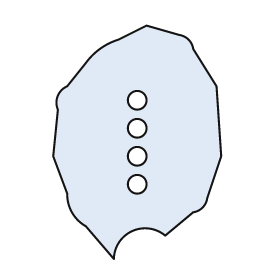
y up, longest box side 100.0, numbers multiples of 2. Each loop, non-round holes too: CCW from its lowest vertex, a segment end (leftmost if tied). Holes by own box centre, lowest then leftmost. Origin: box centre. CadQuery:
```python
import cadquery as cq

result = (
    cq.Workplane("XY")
    .moveTo(-10.0, -50.0)
    .threePointArc((-2.0, -38.0), (12.0, -40.0))
    .lineTo(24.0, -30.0)
    .threePointArc((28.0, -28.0), (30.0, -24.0))
    .lineTo(36.0, -6.0)
    .lineTo(34.0, 24.0)
    .lineTo(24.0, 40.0)
    .threePointArc((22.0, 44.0), (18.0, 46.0))
    .lineTo(4.0, 50.0)
    .lineTo(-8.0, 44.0)
    .threePointArc((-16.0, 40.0), (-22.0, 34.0))
    .lineTo(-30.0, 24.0)
    .threePointArc((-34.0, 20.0), (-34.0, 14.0))
    .lineTo(-36.0, -6.0)
    .lineTo(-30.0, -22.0)
    .threePointArc((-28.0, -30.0), (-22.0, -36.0))
    .close()
    .moveTo(0.0, -18.0)
    .circle(4.0)
    .moveTo(0.0, -6.0)
    .circle(4.0)
    .moveTo(0.0, 6.0)
    .circle(4.0)
    .moveTo(0.0, 18.0)
    .circle(4.0)
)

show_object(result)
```